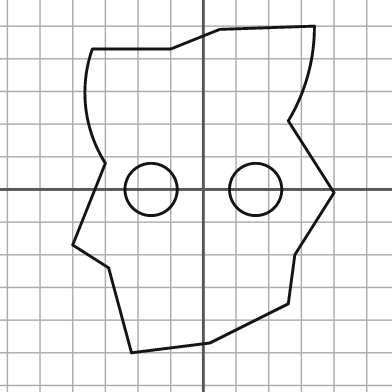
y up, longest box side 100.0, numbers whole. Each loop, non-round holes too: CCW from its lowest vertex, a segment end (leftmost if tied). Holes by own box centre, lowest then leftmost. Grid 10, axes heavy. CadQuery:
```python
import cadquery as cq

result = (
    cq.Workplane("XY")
    .moveTo(-22.0, -50.0)
    .lineTo(2.0, -47.0)
    .lineTo(26.0, -35.0)
    .lineTo(28.0, -20.0)
    .lineTo(40.0, -1.0)
    .lineTo(26.0, 21.0)
    .threePointArc((32.0, 35.0), (34.0, 50.0))
    .lineTo(5.0, 49.0)
    .lineTo(-10.0, 43.0)
    .lineTo(-34.0, 43.0)
    .threePointArc((-36.0, 25.0), (-30.0, 8.0))
    .lineTo(-40.0, -17.0)
    .lineTo(-29.0, -24.0)
    .close()
    .moveTo(-16.0, 0.0)
    .circle(8.0)
    .moveTo(16.0, 0.0)
    .circle(8.0)
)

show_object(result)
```